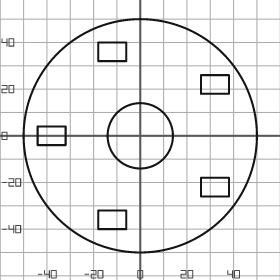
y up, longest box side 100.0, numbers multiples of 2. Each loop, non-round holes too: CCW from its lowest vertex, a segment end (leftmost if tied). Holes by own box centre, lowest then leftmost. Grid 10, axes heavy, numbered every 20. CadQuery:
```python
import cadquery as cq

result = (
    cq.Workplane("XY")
    .moveTo(0.0, 0.0)
    .circle(50.0)
    .moveTo(-18.0, -40.0)
    .lineTo(-6.0, -40.0)
    .lineTo(-6.0, -32.0)
    .lineTo(-18.0, -32.0)
    .close()
    .moveTo(26.0, -26.0)
    .lineTo(38.0, -26.0)
    .lineTo(38.0, -18.0)
    .lineTo(26.0, -18.0)
    .close()
    .moveTo(-44.0, -4.0)
    .lineTo(-32.0, -4.0)
    .lineTo(-32.0, 4.0)
    .lineTo(-44.0, 4.0)
    .close()
    .moveTo(0.0, 0.0)
    .circle(14.0)
    .moveTo(26.0, 18.0)
    .lineTo(38.0, 18.0)
    .lineTo(38.0, 26.0)
    .lineTo(26.0, 26.0)
    .close()
    .moveTo(-18.0, 32.0)
    .lineTo(-6.0, 32.0)
    .lineTo(-6.0, 40.0)
    .lineTo(-18.0, 40.0)
    .close()
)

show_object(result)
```